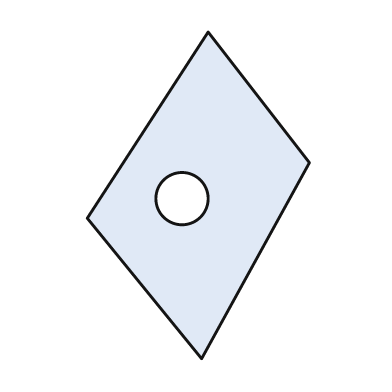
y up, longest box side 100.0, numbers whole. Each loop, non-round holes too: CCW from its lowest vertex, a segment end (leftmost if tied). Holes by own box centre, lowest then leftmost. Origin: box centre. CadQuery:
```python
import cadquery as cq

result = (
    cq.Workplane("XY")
    .moveTo(1.0, -50.0)
    .lineTo(34.0, 10.0)
    .lineTo(3.0, 50.0)
    .lineTo(-34.0, -7.0)
    .close()
    .moveTo(-5.0, -1.0)
    .circle(8.0)
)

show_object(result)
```